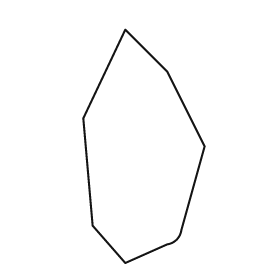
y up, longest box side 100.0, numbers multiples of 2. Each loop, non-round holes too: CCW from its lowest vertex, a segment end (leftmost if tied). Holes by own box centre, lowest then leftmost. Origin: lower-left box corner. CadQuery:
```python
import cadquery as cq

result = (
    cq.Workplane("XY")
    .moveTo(18.0, 0.0)
    .lineTo(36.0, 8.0)
    .threePointArc((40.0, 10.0), (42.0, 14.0))
    .lineTo(52.0, 50.0)
    .lineTo(36.0, 82.0)
    .lineTo(18.0, 100.0)
    .lineTo(0.0, 62.0)
    .lineTo(4.0, 16.0)
    .close()
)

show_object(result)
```